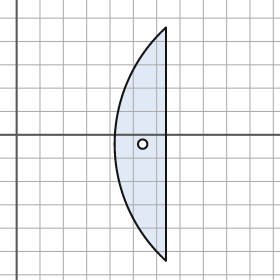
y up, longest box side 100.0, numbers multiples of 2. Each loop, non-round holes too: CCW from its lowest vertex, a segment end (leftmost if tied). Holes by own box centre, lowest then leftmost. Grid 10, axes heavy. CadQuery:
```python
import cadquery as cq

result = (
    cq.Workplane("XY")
    .moveTo(64.0, -54.0)
    .lineTo(64.0, 46.0)
    .threePointArc((42.0, -4.0), (64.0, -54.0))
    .close()
    .moveTo(54.0, -4.0)
    .circle(2.0)
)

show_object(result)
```